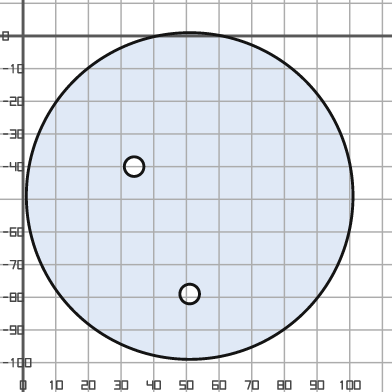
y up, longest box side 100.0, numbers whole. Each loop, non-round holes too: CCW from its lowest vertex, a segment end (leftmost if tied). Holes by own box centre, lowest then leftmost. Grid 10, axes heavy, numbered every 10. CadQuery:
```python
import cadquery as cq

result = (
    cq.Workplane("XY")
    .moveTo(51.0, -49.0)
    .circle(50.0)
    .moveTo(51.0, -79.0)
    .circle(3.0)
    .moveTo(34.0, -40.0)
    .circle(3.0)
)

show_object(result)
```